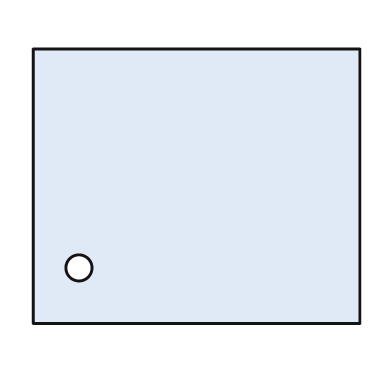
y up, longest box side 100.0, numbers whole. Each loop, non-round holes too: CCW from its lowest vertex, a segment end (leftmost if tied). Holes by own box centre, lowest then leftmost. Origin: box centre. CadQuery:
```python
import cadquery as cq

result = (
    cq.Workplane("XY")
    .moveTo(-50.0, -42.0)
    .lineTo(50.0, -42.0)
    .lineTo(50.0, 42.0)
    .lineTo(-50.0, 42.0)
    .close()
    .moveTo(-36.0, -25.0)
    .circle(4.0)
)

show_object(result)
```